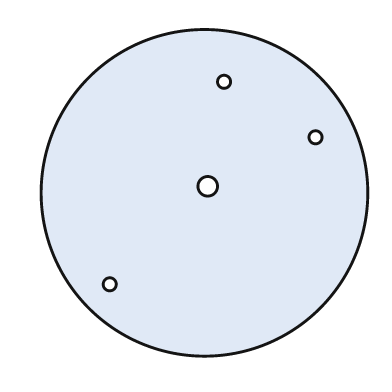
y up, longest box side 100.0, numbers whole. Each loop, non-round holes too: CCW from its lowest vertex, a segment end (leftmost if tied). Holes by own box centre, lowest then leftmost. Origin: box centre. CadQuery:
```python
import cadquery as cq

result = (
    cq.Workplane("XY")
    .moveTo(0.0, 0.0)
    .circle(50.0)
    .moveTo(-29.0, -28.0)
    .circle(2.0)
    .moveTo(1.0, 2.0)
    .circle(3.0)
    .moveTo(34.0, 17.0)
    .circle(2.0)
    .moveTo(6.0, 34.0)
    .circle(2.0)
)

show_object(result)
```